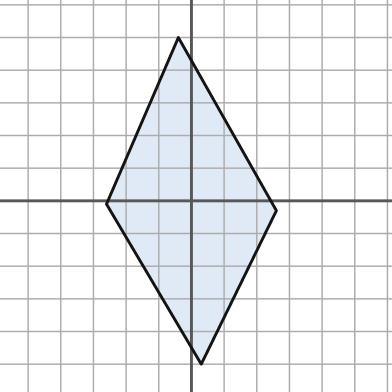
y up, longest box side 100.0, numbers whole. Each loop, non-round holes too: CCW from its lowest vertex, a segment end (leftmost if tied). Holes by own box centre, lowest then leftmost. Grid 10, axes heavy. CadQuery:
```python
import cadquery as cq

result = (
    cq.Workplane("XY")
    .moveTo(3.0, -50.0)
    .lineTo(26.0, -3.0)
    .lineTo(-4.0, 50.0)
    .lineTo(-26.0, -1.0)
    .close()
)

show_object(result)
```